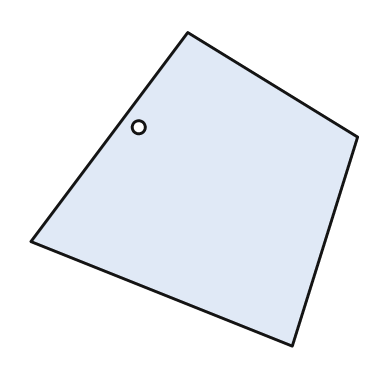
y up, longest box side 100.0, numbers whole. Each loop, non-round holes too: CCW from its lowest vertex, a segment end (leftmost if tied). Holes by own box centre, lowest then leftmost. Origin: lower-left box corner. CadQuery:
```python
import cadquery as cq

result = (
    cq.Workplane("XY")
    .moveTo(80.0, 0.0)
    .lineTo(100.0, 64.0)
    .lineTo(48.0, 96.0)
    .lineTo(0.0, 32.0)
    .close()
    .moveTo(33.0, 67.0)
    .circle(2.0)
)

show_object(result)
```